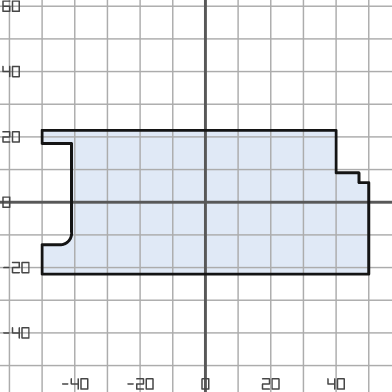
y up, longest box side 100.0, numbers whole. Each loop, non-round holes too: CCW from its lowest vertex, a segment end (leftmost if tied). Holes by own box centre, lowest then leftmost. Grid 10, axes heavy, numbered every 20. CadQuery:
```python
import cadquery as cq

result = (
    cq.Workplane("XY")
    .moveTo(-50.0, -22.0)
    .lineTo(50.0, -22.0)
    .lineTo(50.0, 6.0)
    .lineTo(47.0, 6.0)
    .lineTo(47.0, 9.0)
    .lineTo(40.0, 9.0)
    .lineTo(40.0, 22.0)
    .lineTo(-50.0, 22.0)
    .lineTo(-50.0, 18.0)
    .lineTo(-41.0, 18.0)
    .lineTo(-41.0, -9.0)
    .threePointArc((-42.0, -12.0), (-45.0, -13.0))
    .lineTo(-50.0, -13.0)
    .close()
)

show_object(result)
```